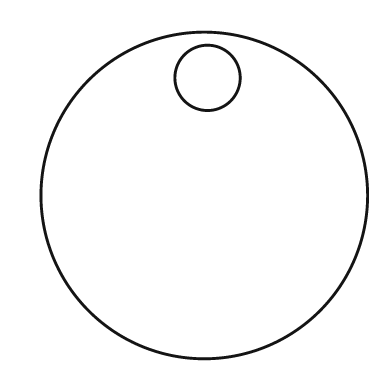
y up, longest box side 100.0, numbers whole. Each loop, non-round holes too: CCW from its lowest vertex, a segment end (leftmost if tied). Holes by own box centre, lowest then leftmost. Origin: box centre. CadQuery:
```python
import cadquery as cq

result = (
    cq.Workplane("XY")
    .moveTo(0.0, 0.0)
    .circle(50.0)
    .moveTo(1.0, 36.0)
    .circle(10.0)
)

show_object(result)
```